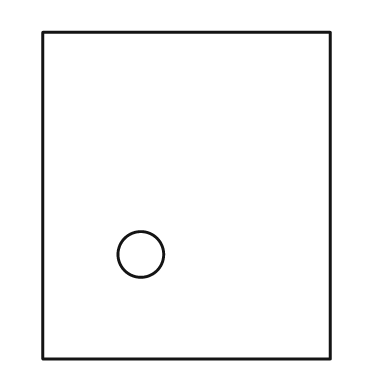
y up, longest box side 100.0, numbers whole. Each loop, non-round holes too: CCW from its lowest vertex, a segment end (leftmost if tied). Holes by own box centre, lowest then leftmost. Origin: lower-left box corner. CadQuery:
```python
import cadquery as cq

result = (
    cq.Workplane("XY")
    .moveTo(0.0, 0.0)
    .lineTo(88.0, 0.0)
    .lineTo(88.0, 100.0)
    .lineTo(0.0, 100.0)
    .close()
    .moveTo(30.0, 32.0)
    .circle(7.0)
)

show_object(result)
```